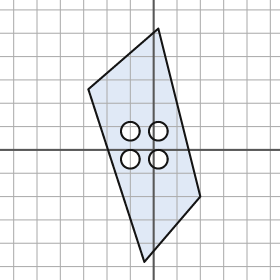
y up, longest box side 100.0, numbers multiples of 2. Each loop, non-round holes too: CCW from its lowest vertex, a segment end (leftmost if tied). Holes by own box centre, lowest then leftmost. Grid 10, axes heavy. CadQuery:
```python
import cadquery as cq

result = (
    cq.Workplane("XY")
    .moveTo(-4.0, -48.0)
    .lineTo(20.0, -20.0)
    .lineTo(2.0, 52.0)
    .lineTo(-28.0, 26.0)
    .close()
    .moveTo(-10.0, -4.0)
    .circle(4.0)
    .moveTo(2.0, -4.0)
    .circle(4.0)
    .moveTo(-10.0, 8.0)
    .circle(4.0)
    .moveTo(2.0, 8.0)
    .circle(4.0)
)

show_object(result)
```